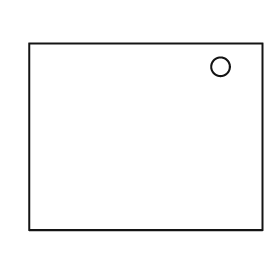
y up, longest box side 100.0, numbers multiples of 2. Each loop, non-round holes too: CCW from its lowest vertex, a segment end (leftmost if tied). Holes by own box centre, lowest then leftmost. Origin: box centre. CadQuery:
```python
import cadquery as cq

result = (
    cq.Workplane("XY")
    .moveTo(-50.0, -40.0)
    .lineTo(50.0, -40.0)
    .lineTo(50.0, 40.0)
    .lineTo(-50.0, 40.0)
    .close()
    .moveTo(32.0, 30.0)
    .circle(4.0)
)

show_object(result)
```